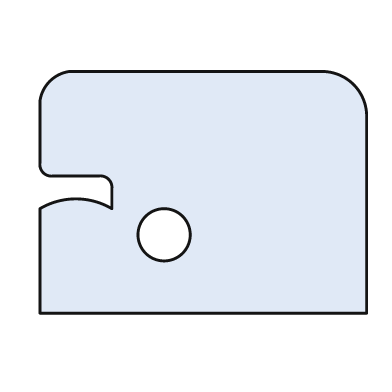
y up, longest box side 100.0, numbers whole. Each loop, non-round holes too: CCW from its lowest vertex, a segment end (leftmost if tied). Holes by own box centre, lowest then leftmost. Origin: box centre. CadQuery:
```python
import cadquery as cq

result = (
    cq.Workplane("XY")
    .moveTo(-50.0, -37.0)
    .lineTo(50.0, -37.0)
    .lineTo(50.0, 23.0)
    .threePointArc((46.0, 33.0), (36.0, 37.0))
    .lineTo(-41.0, 37.0)
    .threePointArc((-47.0, 34.0), (-50.0, 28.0))
    .lineTo(-50.0, 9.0)
    .threePointArc((-49.0, 6.0), (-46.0, 5.0))
    .lineTo(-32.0, 5.0)
    .threePointArc((-29.0, 4.0), (-28.0, 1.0))
    .lineTo(-28.0, -5.0)
    .threePointArc((-39.0, -2.0), (-50.0, -5.0))
    .close()
    .moveTo(-12.0, -13.0)
    .circle(8.0)
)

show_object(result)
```